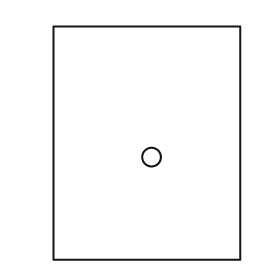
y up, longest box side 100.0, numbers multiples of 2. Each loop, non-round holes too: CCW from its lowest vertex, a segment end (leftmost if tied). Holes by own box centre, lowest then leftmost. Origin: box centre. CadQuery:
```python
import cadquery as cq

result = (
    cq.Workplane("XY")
    .moveTo(-40.0, -50.0)
    .lineTo(40.0, -50.0)
    .lineTo(40.0, 50.0)
    .lineTo(-40.0, 50.0)
    .close()
    .moveTo(2.0, -6.0)
    .circle(4.0)
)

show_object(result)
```